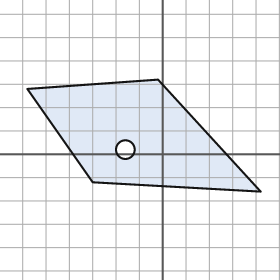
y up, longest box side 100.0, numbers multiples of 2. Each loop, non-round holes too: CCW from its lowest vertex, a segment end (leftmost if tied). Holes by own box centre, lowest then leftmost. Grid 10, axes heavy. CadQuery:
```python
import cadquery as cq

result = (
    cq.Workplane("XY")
    .moveTo(42.0, -16.0)
    .lineTo(-2.0, 32.0)
    .lineTo(-58.0, 28.0)
    .lineTo(-30.0, -12.0)
    .close()
    .moveTo(-16.0, 2.0)
    .circle(4.0)
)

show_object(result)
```